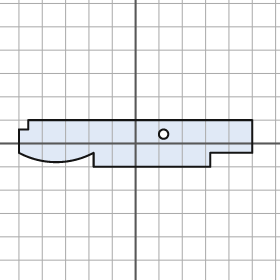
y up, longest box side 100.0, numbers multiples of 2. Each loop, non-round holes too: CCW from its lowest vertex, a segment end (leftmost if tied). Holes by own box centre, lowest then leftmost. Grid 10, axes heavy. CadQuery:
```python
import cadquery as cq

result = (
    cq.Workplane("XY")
    .moveTo(-18.0, -10.0)
    .lineTo(32.0, -10.0)
    .lineTo(32.0, -4.0)
    .lineTo(50.0, -4.0)
    .lineTo(50.0, 10.0)
    .lineTo(-46.0, 10.0)
    .lineTo(-46.0, 6.0)
    .lineTo(-50.0, 6.0)
    .lineTo(-50.0, -4.0)
    .threePointArc((-34.0, -8.0), (-18.0, -4.0))
    .close()
    .moveTo(12.0, 4.0)
    .circle(2.0)
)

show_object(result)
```